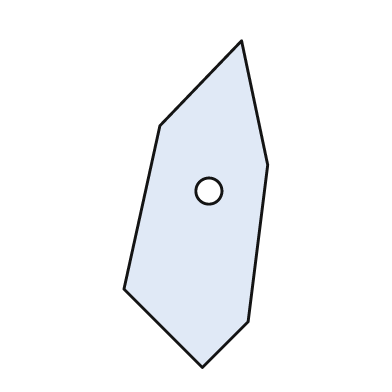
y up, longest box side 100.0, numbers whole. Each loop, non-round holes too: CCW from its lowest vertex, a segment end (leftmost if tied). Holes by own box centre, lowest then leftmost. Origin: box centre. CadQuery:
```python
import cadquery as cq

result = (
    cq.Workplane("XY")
    .moveTo(2.0, -50.0)
    .lineTo(16.0, -36.0)
    .lineTo(22.0, 12.0)
    .lineTo(14.0, 50.0)
    .lineTo(-11.0, 24.0)
    .lineTo(-22.0, -26.0)
    .close()
    .moveTo(4.0, 4.0)
    .circle(4.0)
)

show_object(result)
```